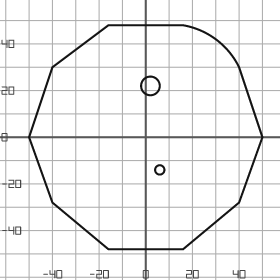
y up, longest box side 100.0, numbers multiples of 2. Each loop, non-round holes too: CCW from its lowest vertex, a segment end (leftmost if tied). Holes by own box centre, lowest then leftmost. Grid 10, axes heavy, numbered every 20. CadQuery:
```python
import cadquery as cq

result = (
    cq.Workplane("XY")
    .moveTo(-16.0, -48.0)
    .lineTo(16.0, -48.0)
    .lineTo(40.0, -28.0)
    .lineTo(50.0, 0.0)
    .lineTo(40.0, 30.0)
    .threePointArc((30.0, 42.0), (16.0, 48.0))
    .lineTo(-16.0, 48.0)
    .lineTo(-40.0, 30.0)
    .lineTo(-50.0, 0.0)
    .lineTo(-40.0, -28.0)
    .close()
    .moveTo(6.0, -14.0)
    .circle(2.0)
    .moveTo(2.0, 22.0)
    .circle(4.0)
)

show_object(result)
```